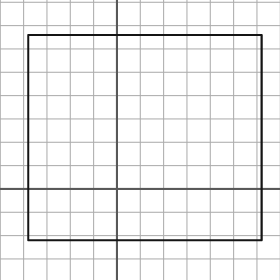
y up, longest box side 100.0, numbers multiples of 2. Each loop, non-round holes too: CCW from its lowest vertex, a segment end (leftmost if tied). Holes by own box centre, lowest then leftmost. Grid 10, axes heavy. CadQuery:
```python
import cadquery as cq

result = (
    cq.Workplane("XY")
    .moveTo(-38.0, -22.0)
    .lineTo(62.0, -22.0)
    .lineTo(62.0, 66.0)
    .lineTo(-38.0, 66.0)
    .close()
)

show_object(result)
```